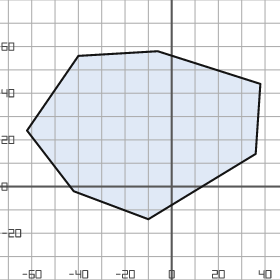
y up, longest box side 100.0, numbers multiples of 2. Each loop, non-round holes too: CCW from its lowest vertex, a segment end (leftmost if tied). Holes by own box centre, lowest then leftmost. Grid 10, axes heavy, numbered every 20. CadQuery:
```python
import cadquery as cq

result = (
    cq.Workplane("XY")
    .moveTo(-10.0, -14.0)
    .lineTo(36.0, 14.0)
    .lineTo(38.0, 44.0)
    .lineTo(-6.0, 58.0)
    .lineTo(-40.0, 56.0)
    .lineTo(-62.0, 24.0)
    .lineTo(-42.0, -2.0)
    .close()
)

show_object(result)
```